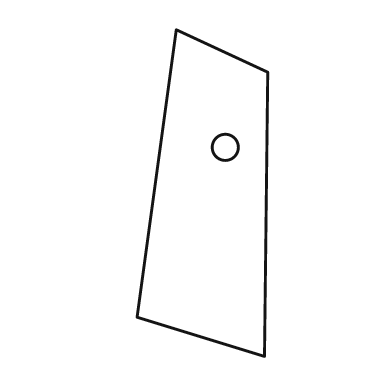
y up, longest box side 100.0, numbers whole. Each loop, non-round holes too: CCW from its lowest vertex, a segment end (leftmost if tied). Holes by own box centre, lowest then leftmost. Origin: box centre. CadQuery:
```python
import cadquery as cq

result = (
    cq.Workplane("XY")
    .moveTo(19.0, -50.0)
    .lineTo(20.0, 37.0)
    .lineTo(-8.0, 50.0)
    .lineTo(-20.0, -38.0)
    .close()
    .moveTo(7.0, 14.0)
    .circle(4.0)
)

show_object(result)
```